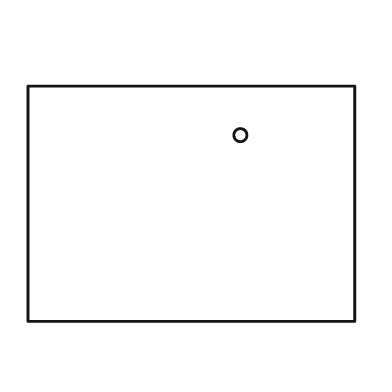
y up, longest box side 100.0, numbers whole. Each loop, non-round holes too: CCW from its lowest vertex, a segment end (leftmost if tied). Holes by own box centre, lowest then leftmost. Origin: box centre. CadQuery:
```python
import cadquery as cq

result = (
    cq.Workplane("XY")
    .moveTo(-50.0, -36.0)
    .lineTo(50.0, -36.0)
    .lineTo(50.0, 36.0)
    .lineTo(-50.0, 36.0)
    .close()
    .moveTo(15.0, 21.0)
    .circle(2.0)
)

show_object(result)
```